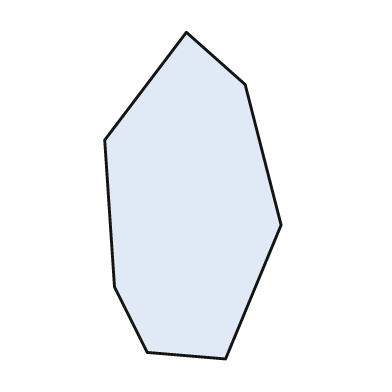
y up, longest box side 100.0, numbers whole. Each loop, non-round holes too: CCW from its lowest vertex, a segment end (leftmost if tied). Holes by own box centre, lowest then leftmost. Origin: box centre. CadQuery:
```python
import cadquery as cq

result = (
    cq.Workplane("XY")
    .moveTo(10.0, -50.0)
    .lineTo(27.0, -9.0)
    .lineTo(16.0, 34.0)
    .lineTo(-2.0, 50.0)
    .lineTo(-27.0, 17.0)
    .lineTo(-24.0, -28.0)
    .lineTo(-14.0, -48.0)
    .close()
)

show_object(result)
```